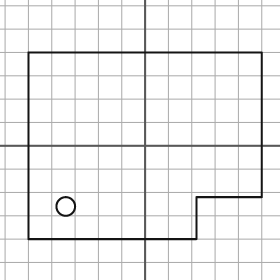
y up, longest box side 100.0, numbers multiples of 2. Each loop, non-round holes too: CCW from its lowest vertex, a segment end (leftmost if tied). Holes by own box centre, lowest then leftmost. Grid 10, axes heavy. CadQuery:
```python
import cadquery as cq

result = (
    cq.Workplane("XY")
    .moveTo(-50.0, -40.0)
    .lineTo(22.0, -40.0)
    .lineTo(22.0, -22.0)
    .lineTo(50.0, -22.0)
    .lineTo(50.0, 40.0)
    .lineTo(-50.0, 40.0)
    .close()
    .moveTo(-34.0, -26.0)
    .circle(4.0)
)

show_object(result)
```